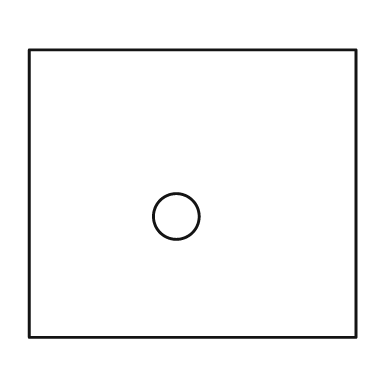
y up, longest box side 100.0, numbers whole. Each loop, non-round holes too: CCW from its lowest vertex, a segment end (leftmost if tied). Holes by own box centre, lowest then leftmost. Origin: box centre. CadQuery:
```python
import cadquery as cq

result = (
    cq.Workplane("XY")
    .moveTo(-50.0, -44.0)
    .lineTo(50.0, -44.0)
    .lineTo(50.0, 44.0)
    .lineTo(-50.0, 44.0)
    .close()
    .moveTo(-5.0, -7.0)
    .circle(7.0)
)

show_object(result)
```